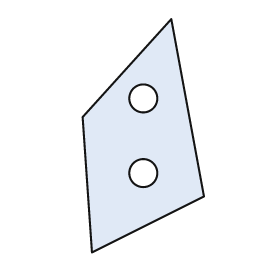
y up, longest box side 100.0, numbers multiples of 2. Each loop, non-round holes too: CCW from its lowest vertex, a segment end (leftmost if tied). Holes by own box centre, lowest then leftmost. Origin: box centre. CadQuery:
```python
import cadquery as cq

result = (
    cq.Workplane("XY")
    .moveTo(-22.0, -50.0)
    .lineTo(26.0, -26.0)
    .lineTo(12.0, 50.0)
    .lineTo(-26.0, 8.0)
    .close()
    .moveTo(0.0, -16.0)
    .circle(6.0)
    .moveTo(0.0, 16.0)
    .circle(6.0)
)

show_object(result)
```